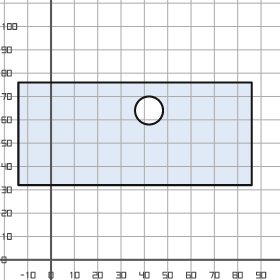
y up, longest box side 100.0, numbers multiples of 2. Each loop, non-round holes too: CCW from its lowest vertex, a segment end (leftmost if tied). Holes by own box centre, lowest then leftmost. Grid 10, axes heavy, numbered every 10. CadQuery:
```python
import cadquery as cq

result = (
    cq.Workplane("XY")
    .moveTo(-14.0, 32.0)
    .lineTo(86.0, 32.0)
    .lineTo(86.0, 76.0)
    .lineTo(-14.0, 76.0)
    .close()
    .moveTo(42.0, 64.0)
    .circle(6.0)
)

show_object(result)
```